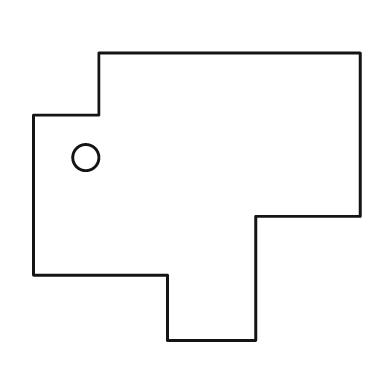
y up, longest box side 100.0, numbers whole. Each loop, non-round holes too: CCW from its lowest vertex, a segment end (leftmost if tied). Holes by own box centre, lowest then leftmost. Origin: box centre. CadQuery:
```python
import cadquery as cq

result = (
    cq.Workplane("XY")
    .moveTo(-9.0, -44.0)
    .lineTo(18.0, -44.0)
    .lineTo(18.0, -6.0)
    .lineTo(50.0, -6.0)
    .lineTo(50.0, 44.0)
    .lineTo(-30.0, 44.0)
    .lineTo(-30.0, 25.0)
    .lineTo(-50.0, 25.0)
    .lineTo(-50.0, -24.0)
    .lineTo(-9.0, -24.0)
    .close()
    .moveTo(-34.0, 12.0)
    .circle(4.0)
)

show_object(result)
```